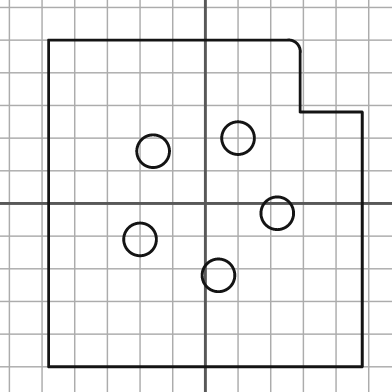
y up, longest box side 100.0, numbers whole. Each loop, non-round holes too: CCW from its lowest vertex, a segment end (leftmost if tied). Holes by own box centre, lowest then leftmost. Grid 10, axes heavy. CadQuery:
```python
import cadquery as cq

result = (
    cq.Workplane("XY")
    .moveTo(-48.0, -50.0)
    .lineTo(48.0, -50.0)
    .lineTo(48.0, 28.0)
    .lineTo(29.0, 28.0)
    .lineTo(29.0, 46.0)
    .threePointArc((28.0, 49.0), (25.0, 50.0))
    .lineTo(-48.0, 50.0)
    .close()
    .moveTo(4.0, -22.0)
    .circle(5.0)
    .moveTo(-20.0, -11.0)
    .circle(5.0)
    .moveTo(22.0, -3.0)
    .circle(5.0)
    .moveTo(-16.0, 16.0)
    .circle(5.0)
    .moveTo(10.0, 20.0)
    .circle(5.0)
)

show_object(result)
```